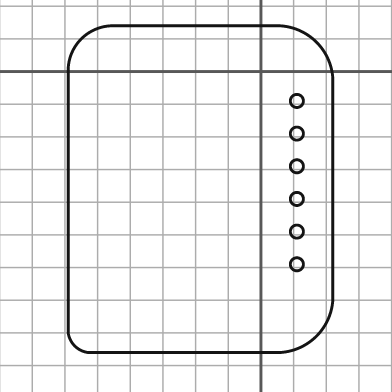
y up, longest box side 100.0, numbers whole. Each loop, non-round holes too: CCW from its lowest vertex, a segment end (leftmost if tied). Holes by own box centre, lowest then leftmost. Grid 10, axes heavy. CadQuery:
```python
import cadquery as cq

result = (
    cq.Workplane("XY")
    .moveTo(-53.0, -86.0)
    .lineTo(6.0, -86.0)
    .threePointArc((17.0, -81.0), (22.0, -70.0))
    .lineTo(22.0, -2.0)
    .threePointArc((17.0, 9.0), (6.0, 14.0))
    .lineTo(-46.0, 14.0)
    .threePointArc((-55.0, 10.0), (-59.0, 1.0))
    .lineTo(-59.0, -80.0)
    .threePointArc((-57.0, -84.0), (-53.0, -86.0))
    .close()
    .moveTo(11.0, -59.0)
    .circle(2.0)
    .moveTo(11.0, -49.0)
    .circle(2.0)
    .moveTo(11.0, -39.0)
    .circle(2.0)
    .moveTo(11.0, -29.0)
    .circle(2.0)
    .moveTo(11.0, -19.0)
    .circle(2.0)
    .moveTo(11.0, -9.0)
    .circle(2.0)
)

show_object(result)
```